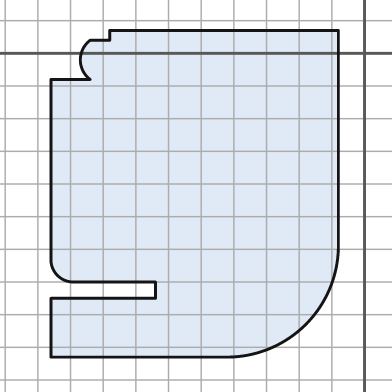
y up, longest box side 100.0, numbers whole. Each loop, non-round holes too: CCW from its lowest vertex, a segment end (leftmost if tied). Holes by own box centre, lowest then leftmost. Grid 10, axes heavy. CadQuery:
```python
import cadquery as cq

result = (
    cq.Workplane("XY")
    .moveTo(-96.0, -93.0)
    .lineTo(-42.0, -93.0)
    .threePointArc((-18.0, -83.0), (-8.0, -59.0))
    .lineTo(-8.0, 7.0)
    .lineTo(-78.0, 7.0)
    .lineTo(-78.0, 4.0)
    .lineTo(-84.0, 4.0)
    .threePointArc((-87.0, -2.0), (-84.0, -8.0))
    .lineTo(-96.0, -8.0)
    .lineTo(-96.0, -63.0)
    .threePointArc((-94.0, -68.0), (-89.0, -70.0))
    .lineTo(-64.0, -70.0)
    .lineTo(-64.0, -75.0)
    .lineTo(-96.0, -75.0)
    .close()
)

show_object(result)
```